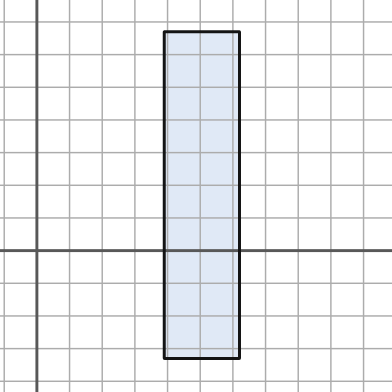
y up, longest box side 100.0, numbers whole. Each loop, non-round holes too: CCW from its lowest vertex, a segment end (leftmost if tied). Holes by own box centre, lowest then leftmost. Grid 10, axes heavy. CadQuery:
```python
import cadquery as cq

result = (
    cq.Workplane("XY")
    .moveTo(39.0, -33.0)
    .lineTo(62.0, -33.0)
    .lineTo(62.0, 67.0)
    .lineTo(39.0, 67.0)
    .close()
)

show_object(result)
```